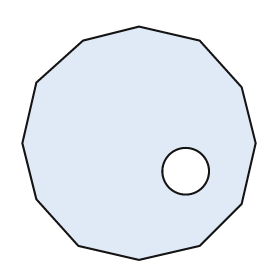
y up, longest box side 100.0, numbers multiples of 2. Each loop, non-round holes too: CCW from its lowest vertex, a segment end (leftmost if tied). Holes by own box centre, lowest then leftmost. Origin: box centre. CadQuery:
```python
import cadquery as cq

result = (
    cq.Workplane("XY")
    .moveTo(0.0, -50.0)
    .lineTo(26.0, -44.0)
    .lineTo(44.0, -26.0)
    .lineTo(50.0, 0.0)
    .lineTo(44.0, 24.0)
    .lineTo(26.0, 44.0)
    .lineTo(0.0, 50.0)
    .lineTo(-24.0, 44.0)
    .lineTo(-44.0, 26.0)
    .lineTo(-50.0, 0.0)
    .lineTo(-44.0, -24.0)
    .lineTo(-26.0, -44.0)
    .close()
    .moveTo(20.0, -12.0)
    .circle(10.0)
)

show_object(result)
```